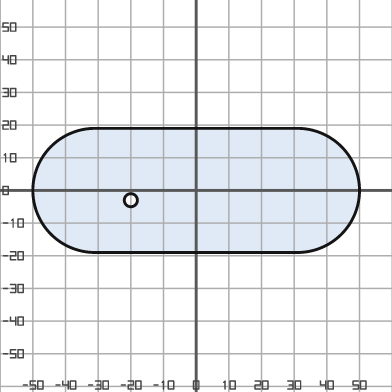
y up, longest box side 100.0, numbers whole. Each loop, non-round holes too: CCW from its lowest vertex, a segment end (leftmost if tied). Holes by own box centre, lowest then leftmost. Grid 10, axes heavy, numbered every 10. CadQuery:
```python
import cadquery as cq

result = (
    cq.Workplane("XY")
    .moveTo(-31.0, -19.0)
    .lineTo(31.0, -19.0)
    .threePointArc((50.0, 0.0), (31.0, 19.0))
    .lineTo(-31.0, 19.0)
    .threePointArc((-50.0, 0.0), (-31.0, -19.0))
    .close()
    .moveTo(-20.0, -3.0)
    .circle(2.0)
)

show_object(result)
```